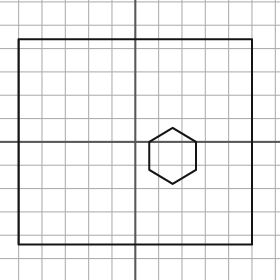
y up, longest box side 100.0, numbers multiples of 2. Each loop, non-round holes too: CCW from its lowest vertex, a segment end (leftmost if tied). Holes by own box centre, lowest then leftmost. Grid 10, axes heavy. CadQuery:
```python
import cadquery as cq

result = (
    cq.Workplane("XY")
    .moveTo(-50.0, -44.0)
    .lineTo(50.0, -44.0)
    .lineTo(50.0, 44.0)
    .lineTo(-50.0, 44.0)
    .close()
    .moveTo(16.0, -18.0)
    .lineTo(26.0, -12.0)
    .lineTo(26.0, 0.0)
    .lineTo(16.0, 6.0)
    .lineTo(6.0, 0.0)
    .lineTo(6.0, -12.0)
    .close()
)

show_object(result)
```